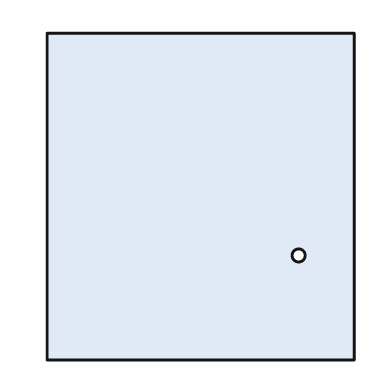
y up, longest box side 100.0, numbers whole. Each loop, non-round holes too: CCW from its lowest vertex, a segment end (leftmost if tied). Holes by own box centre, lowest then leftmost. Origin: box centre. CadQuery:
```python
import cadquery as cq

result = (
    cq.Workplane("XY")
    .moveTo(-47.0, -50.0)
    .lineTo(47.0, -50.0)
    .lineTo(47.0, 50.0)
    .lineTo(-47.0, 50.0)
    .close()
    .moveTo(30.0, -18.0)
    .circle(2.0)
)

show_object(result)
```